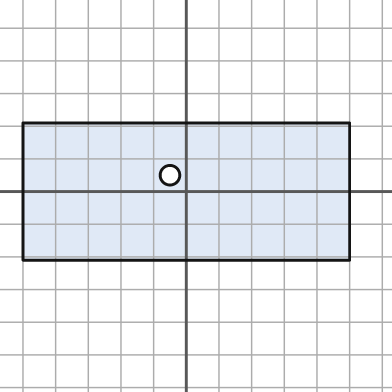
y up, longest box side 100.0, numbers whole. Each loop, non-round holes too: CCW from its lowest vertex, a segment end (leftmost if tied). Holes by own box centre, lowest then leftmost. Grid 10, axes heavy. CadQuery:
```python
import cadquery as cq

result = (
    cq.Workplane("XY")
    .moveTo(-50.0, -21.0)
    .lineTo(50.0, -21.0)
    .lineTo(50.0, 21.0)
    .lineTo(-50.0, 21.0)
    .close()
    .moveTo(-5.0, 5.0)
    .circle(3.0)
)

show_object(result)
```